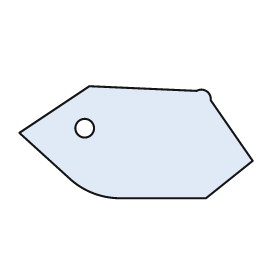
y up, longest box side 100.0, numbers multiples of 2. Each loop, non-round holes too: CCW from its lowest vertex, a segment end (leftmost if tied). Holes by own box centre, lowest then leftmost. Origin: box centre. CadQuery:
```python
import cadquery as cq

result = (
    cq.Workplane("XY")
    .moveTo(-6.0, -24.0)
    .lineTo(30.0, -24.0)
    .lineTo(50.0, -8.0)
    .lineTo(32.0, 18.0)
    .threePointArc((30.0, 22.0), (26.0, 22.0))
    .lineTo(-20.0, 24.0)
    .lineTo(-50.0, 4.0)
    .lineTo(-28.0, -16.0)
    .threePointArc((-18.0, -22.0), (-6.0, -24.0))
    .close()
    .moveTo(-22.0, 6.0)
    .circle(4.0)
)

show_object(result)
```